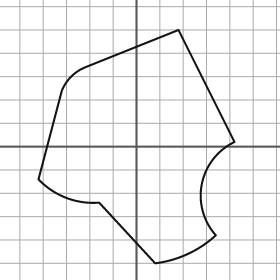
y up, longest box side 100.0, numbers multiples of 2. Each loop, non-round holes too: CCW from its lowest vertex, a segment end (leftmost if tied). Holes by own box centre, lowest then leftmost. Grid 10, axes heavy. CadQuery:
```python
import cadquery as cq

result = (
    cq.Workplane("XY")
    .moveTo(8.0, -50.0)
    .threePointArc((22.0, -46.0), (34.0, -38.0))
    .threePointArc((28.0, -16.0), (42.0, 2.0))
    .lineTo(18.0, 50.0)
    .lineTo(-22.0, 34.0)
    .threePointArc((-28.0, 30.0), (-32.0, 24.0))
    .lineTo(-42.0, -14.0)
    .threePointArc((-30.0, -22.0), (-16.0, -24.0))
    .close()
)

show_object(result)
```